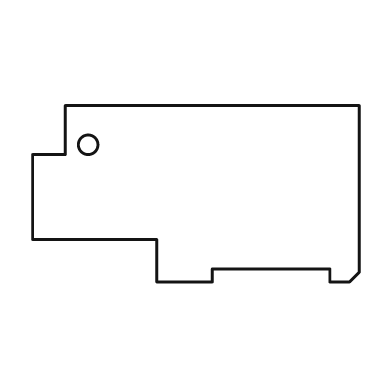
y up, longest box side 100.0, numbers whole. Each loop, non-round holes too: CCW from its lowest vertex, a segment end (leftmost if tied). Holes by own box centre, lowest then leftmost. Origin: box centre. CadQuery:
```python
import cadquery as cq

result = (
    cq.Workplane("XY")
    .moveTo(-12.0, -27.0)
    .lineTo(5.0, -27.0)
    .lineTo(5.0, -23.0)
    .lineTo(41.0, -23.0)
    .lineTo(41.0, -27.0)
    .lineTo(47.0, -27.0)
    .lineTo(50.0, -24.0)
    .lineTo(50.0, 27.0)
    .lineTo(-40.0, 27.0)
    .lineTo(-40.0, 12.0)
    .lineTo(-50.0, 12.0)
    .lineTo(-50.0, -14.0)
    .lineTo(-12.0, -14.0)
    .close()
    .moveTo(-33.0, 15.0)
    .circle(3.0)
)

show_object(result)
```